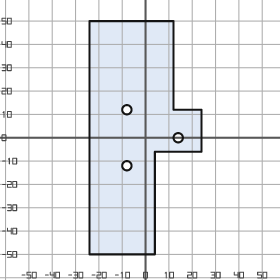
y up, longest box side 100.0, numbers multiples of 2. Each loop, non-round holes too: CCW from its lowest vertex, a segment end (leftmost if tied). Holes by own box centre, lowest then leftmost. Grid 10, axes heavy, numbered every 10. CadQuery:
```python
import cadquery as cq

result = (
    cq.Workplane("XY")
    .moveTo(-24.0, -50.0)
    .lineTo(4.0, -50.0)
    .lineTo(4.0, -6.0)
    .lineTo(24.0, -6.0)
    .lineTo(24.0, 12.0)
    .lineTo(12.0, 12.0)
    .lineTo(12.0, 50.0)
    .lineTo(-24.0, 50.0)
    .close()
    .moveTo(-8.0, -12.0)
    .circle(2.0)
    .moveTo(14.0, 0.0)
    .circle(2.0)
    .moveTo(-8.0, 12.0)
    .circle(2.0)
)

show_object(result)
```